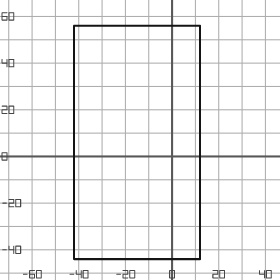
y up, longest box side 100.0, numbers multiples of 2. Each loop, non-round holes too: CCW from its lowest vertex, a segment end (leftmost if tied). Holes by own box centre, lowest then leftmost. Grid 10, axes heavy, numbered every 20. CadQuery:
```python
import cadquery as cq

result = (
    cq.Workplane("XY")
    .moveTo(-42.0, -44.0)
    .lineTo(12.0, -44.0)
    .lineTo(12.0, 56.0)
    .lineTo(-42.0, 56.0)
    .close()
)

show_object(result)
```